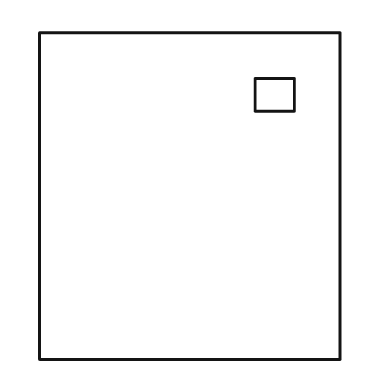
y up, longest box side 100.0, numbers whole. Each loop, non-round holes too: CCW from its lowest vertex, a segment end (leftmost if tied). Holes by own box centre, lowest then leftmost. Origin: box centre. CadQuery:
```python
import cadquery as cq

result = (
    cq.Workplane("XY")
    .moveTo(-46.0, -50.0)
    .lineTo(46.0, -50.0)
    .lineTo(46.0, 50.0)
    .lineTo(-46.0, 50.0)
    .close()
    .moveTo(20.0, 26.0)
    .lineTo(32.0, 26.0)
    .lineTo(32.0, 36.0)
    .lineTo(20.0, 36.0)
    .close()
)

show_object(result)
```